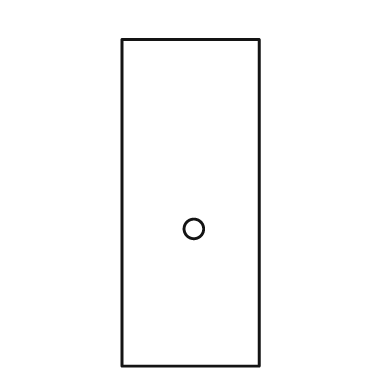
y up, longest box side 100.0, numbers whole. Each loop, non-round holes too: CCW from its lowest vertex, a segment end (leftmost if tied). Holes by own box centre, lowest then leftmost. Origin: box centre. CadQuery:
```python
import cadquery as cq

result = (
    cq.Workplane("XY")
    .moveTo(-21.0, -50.0)
    .lineTo(21.0, -50.0)
    .lineTo(21.0, 50.0)
    .lineTo(-21.0, 50.0)
    .close()
    .moveTo(1.0, -8.0)
    .circle(3.0)
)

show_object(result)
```